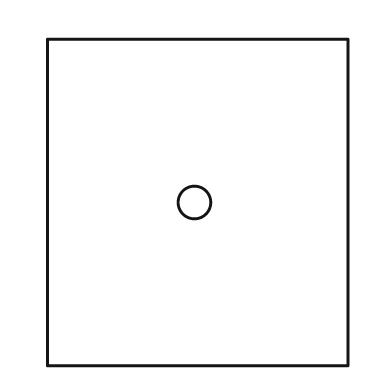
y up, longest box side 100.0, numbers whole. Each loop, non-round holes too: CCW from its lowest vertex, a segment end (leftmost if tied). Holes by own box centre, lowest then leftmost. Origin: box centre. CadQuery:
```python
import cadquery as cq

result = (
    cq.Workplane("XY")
    .moveTo(-46.0, -50.0)
    .lineTo(46.0, -50.0)
    .lineTo(46.0, 50.0)
    .lineTo(-46.0, 50.0)
    .close()
    .moveTo(-1.0, 0.0)
    .circle(5.0)
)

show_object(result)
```